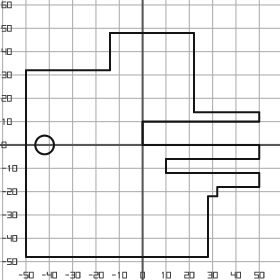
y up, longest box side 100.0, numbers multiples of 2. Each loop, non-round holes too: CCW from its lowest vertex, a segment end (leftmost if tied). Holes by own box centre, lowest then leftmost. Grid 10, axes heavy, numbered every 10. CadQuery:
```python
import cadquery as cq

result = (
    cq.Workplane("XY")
    .moveTo(-50.0, -48.0)
    .lineTo(28.0, -48.0)
    .lineTo(28.0, -22.0)
    .lineTo(32.0, -22.0)
    .lineTo(32.0, -18.0)
    .lineTo(50.0, -18.0)
    .lineTo(50.0, -12.0)
    .lineTo(10.0, -12.0)
    .lineTo(10.0, -6.0)
    .lineTo(50.0, -6.0)
    .lineTo(50.0, 0.0)
    .lineTo(0.0, 0.0)
    .lineTo(0.0, 10.0)
    .lineTo(50.0, 10.0)
    .lineTo(50.0, 14.0)
    .lineTo(22.0, 14.0)
    .lineTo(22.0, 48.0)
    .lineTo(-14.0, 48.0)
    .lineTo(-14.0, 32.0)
    .lineTo(-50.0, 32.0)
    .close()
    .moveTo(-42.0, 0.0)
    .circle(4.0)
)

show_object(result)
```